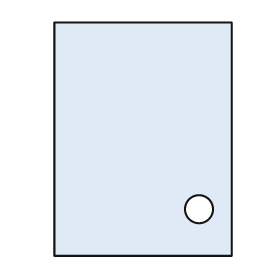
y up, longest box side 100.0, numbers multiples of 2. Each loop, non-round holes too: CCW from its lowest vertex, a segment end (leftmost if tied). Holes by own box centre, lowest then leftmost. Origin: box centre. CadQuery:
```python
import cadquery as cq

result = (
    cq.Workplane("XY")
    .moveTo(-38.0, -50.0)
    .lineTo(38.0, -50.0)
    .lineTo(38.0, 50.0)
    .lineTo(-38.0, 50.0)
    .close()
    .moveTo(24.0, -30.0)
    .circle(6.0)
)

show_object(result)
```